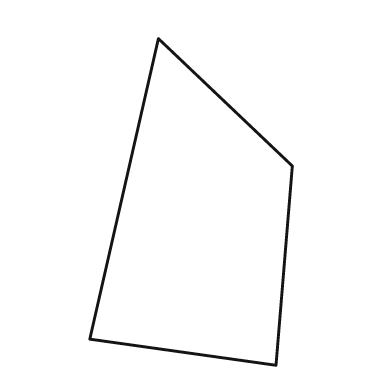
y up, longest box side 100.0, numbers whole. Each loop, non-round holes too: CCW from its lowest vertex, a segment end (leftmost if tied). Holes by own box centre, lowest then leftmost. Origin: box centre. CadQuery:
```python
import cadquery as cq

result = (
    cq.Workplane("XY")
    .moveTo(26.0, -50.0)
    .lineTo(31.0, 11.0)
    .lineTo(-10.0, 50.0)
    .lineTo(-31.0, -42.0)
    .close()
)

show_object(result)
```